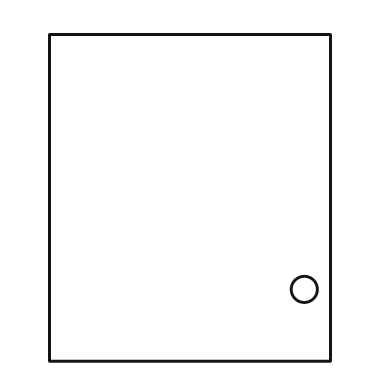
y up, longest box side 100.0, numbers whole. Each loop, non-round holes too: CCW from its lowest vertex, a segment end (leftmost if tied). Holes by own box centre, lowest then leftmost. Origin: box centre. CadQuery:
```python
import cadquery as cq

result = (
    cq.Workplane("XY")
    .moveTo(-43.0, -50.0)
    .lineTo(43.0, -50.0)
    .lineTo(43.0, 50.0)
    .lineTo(-43.0, 50.0)
    .close()
    .moveTo(35.0, -28.0)
    .circle(4.0)
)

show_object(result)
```